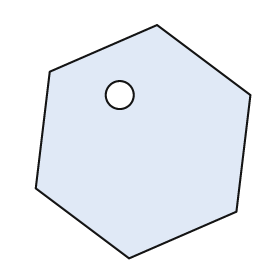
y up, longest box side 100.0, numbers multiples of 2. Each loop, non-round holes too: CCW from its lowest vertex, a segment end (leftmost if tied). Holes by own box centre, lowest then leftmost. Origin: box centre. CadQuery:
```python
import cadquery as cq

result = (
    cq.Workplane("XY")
    .moveTo(-6.0, -50.0)
    .lineTo(40.0, -30.0)
    .lineTo(46.0, 20.0)
    .lineTo(6.0, 50.0)
    .lineTo(-40.0, 30.0)
    .lineTo(-46.0, -20.0)
    .close()
    .moveTo(-10.0, 20.0)
    .circle(6.0)
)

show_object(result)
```